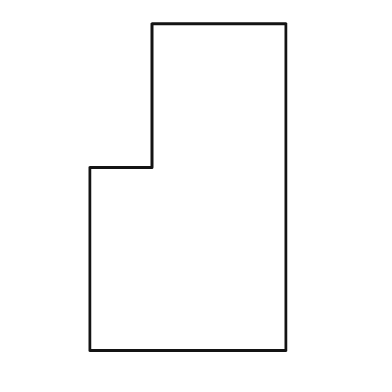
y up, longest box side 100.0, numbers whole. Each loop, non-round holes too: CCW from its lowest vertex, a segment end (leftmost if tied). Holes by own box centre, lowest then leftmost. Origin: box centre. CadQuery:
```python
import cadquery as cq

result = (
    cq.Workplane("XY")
    .moveTo(-30.0, -50.0)
    .lineTo(30.0, -50.0)
    .lineTo(30.0, 50.0)
    .lineTo(-11.0, 50.0)
    .lineTo(-11.0, 6.0)
    .lineTo(-30.0, 6.0)
    .close()
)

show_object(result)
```